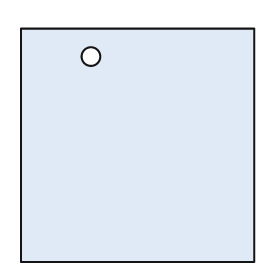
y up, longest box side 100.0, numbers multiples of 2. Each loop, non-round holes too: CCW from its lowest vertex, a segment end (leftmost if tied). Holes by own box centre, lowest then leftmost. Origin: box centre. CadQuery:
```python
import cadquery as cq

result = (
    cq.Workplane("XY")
    .moveTo(-50.0, -50.0)
    .lineTo(50.0, -50.0)
    .lineTo(50.0, 50.0)
    .lineTo(-50.0, 50.0)
    .close()
    .moveTo(-20.0, 38.0)
    .circle(4.0)
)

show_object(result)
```